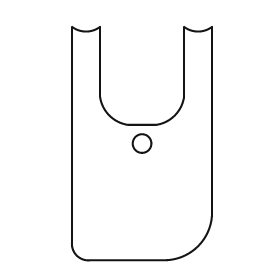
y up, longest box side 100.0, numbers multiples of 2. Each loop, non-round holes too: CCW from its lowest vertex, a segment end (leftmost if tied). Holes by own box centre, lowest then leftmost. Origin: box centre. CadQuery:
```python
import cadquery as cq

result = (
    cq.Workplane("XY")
    .moveTo(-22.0, -50.0)
    .lineTo(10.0, -50.0)
    .threePointArc((24.0, -44.0), (30.0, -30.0))
    .lineTo(30.0, 50.0)
    .threePointArc((24.0, 48.0), (18.0, 50.0))
    .lineTo(18.0, 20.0)
    .threePointArc((14.0, 12.0), (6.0, 8.0))
    .lineTo(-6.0, 8.0)
    .threePointArc((-14.0, 12.0), (-18.0, 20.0))
    .lineTo(-18.0, 50.0)
    .threePointArc((-24.0, 48.0), (-30.0, 50.0))
    .lineTo(-30.0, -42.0)
    .threePointArc((-28.0, -48.0), (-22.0, -50.0))
    .close()
    .moveTo(0.0, 0.0)
    .circle(4.0)
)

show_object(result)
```